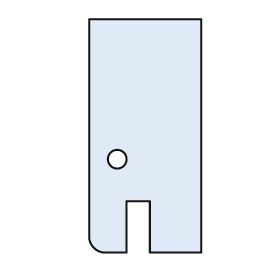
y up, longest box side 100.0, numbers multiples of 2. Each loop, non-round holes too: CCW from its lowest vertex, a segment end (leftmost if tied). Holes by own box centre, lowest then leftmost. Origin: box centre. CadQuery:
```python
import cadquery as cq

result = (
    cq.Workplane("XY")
    .moveTo(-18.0, -50.0)
    .lineTo(-8.0, -50.0)
    .lineTo(-8.0, -28.0)
    .lineTo(2.0, -28.0)
    .lineTo(2.0, -50.0)
    .lineTo(24.0, -50.0)
    .lineTo(24.0, 50.0)
    .lineTo(-24.0, 50.0)
    .lineTo(-24.0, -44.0)
    .threePointArc((-22.0, -48.0), (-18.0, -50.0))
    .close()
    .moveTo(-12.0, -10.0)
    .circle(4.0)
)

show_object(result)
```